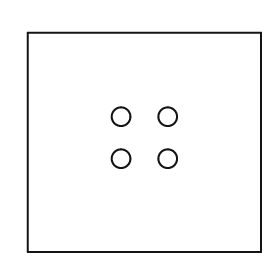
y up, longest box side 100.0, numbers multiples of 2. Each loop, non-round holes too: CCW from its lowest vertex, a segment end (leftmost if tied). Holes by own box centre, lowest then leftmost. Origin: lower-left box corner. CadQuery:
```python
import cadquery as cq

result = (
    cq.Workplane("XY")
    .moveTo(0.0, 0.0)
    .lineTo(100.0, 0.0)
    .lineTo(100.0, 94.0)
    .lineTo(0.0, 94.0)
    .close()
    .moveTo(40.0, 40.0)
    .circle(4.0)
    .moveTo(60.0, 40.0)
    .circle(4.0)
    .moveTo(40.0, 58.0)
    .circle(4.0)
    .moveTo(60.0, 58.0)
    .circle(4.0)
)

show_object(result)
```